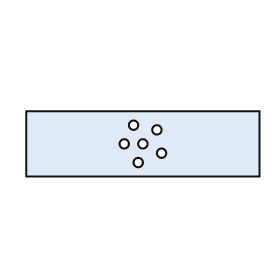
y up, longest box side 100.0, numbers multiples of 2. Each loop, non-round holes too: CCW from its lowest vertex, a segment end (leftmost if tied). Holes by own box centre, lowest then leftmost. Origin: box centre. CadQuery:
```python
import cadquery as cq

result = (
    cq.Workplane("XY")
    .moveTo(-50.0, -14.0)
    .lineTo(50.0, -14.0)
    .lineTo(50.0, 14.0)
    .lineTo(-50.0, 14.0)
    .close()
    .moveTo(-2.0, -8.0)
    .circle(2.0)
    .moveTo(8.0, -4.0)
    .circle(2.0)
    .moveTo(-8.0, 0.0)
    .circle(2.0)
    .moveTo(0.0, 0.0)
    .circle(2.0)
    .moveTo(6.0, 6.0)
    .circle(2.0)
    .moveTo(-4.0, 8.0)
    .circle(2.0)
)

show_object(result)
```